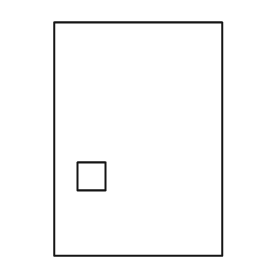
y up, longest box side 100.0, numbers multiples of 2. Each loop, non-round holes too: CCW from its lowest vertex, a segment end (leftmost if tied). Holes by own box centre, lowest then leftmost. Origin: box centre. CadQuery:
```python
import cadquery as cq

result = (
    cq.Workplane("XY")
    .moveTo(-36.0, -50.0)
    .lineTo(36.0, -50.0)
    .lineTo(36.0, 50.0)
    .lineTo(-36.0, 50.0)
    .close()
    .moveTo(-26.0, -22.0)
    .lineTo(-14.0, -22.0)
    .lineTo(-14.0, -10.0)
    .lineTo(-26.0, -10.0)
    .close()
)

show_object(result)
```